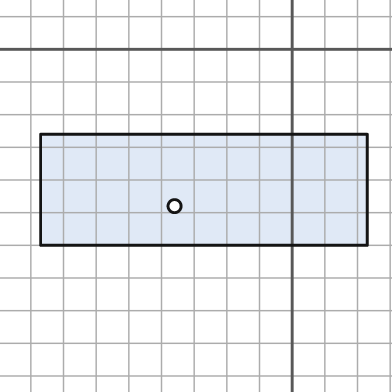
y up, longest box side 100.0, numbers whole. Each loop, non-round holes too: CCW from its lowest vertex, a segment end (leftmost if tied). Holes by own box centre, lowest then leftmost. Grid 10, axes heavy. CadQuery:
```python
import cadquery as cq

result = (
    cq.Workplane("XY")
    .moveTo(-77.0, -60.0)
    .lineTo(23.0, -60.0)
    .lineTo(23.0, -26.0)
    .lineTo(-77.0, -26.0)
    .close()
    .moveTo(-36.0, -48.0)
    .circle(2.0)
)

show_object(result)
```